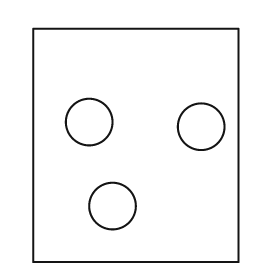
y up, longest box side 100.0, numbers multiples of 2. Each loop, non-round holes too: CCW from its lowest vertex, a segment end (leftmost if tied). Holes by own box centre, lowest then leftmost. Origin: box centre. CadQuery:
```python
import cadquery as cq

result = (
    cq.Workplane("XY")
    .moveTo(-44.0, -50.0)
    .lineTo(44.0, -50.0)
    .lineTo(44.0, 50.0)
    .lineTo(-44.0, 50.0)
    .close()
    .moveTo(-10.0, -26.0)
    .circle(10.0)
    .moveTo(28.0, 8.0)
    .circle(10.0)
    .moveTo(-20.0, 10.0)
    .circle(10.0)
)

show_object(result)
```